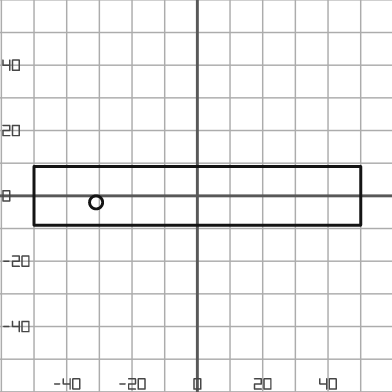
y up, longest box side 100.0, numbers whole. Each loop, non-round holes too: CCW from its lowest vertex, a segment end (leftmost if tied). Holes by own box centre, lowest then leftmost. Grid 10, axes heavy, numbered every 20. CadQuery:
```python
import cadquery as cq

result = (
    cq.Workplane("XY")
    .moveTo(-50.0, -9.0)
    .lineTo(50.0, -9.0)
    .lineTo(50.0, 9.0)
    .lineTo(-50.0, 9.0)
    .close()
    .moveTo(-31.0, -2.0)
    .circle(2.0)
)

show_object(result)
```